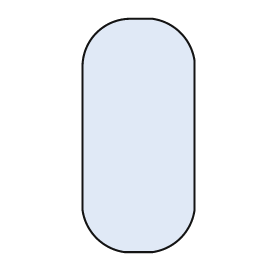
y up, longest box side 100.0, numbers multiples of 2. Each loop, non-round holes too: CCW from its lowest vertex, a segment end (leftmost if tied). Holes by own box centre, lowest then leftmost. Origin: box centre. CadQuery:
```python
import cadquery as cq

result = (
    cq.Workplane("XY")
    .moveTo(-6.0, -50.0)
    .lineTo(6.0, -50.0)
    .threePointArc((18.0, -44.0), (24.0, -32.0))
    .lineTo(24.0, 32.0)
    .threePointArc((18.0, 44.0), (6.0, 50.0))
    .lineTo(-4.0, 50.0)
    .threePointArc((-18.0, 44.0), (-24.0, 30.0))
    .lineTo(-24.0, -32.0)
    .threePointArc((-18.0, -44.0), (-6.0, -50.0))
    .close()
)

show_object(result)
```